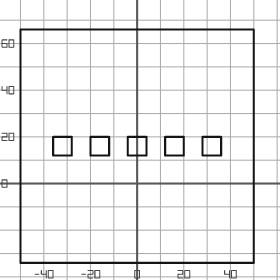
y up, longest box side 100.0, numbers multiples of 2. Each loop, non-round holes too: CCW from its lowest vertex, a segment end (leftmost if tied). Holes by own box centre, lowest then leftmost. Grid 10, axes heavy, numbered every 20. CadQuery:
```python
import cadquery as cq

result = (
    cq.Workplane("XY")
    .moveTo(-50.0, -34.0)
    .lineTo(50.0, -34.0)
    .lineTo(50.0, 66.0)
    .lineTo(-50.0, 66.0)
    .close()
    .moveTo(-36.0, 12.0)
    .lineTo(-28.0, 12.0)
    .lineTo(-28.0, 20.0)
    .lineTo(-36.0, 20.0)
    .close()
    .moveTo(-20.0, 12.0)
    .lineTo(-12.0, 12.0)
    .lineTo(-12.0, 20.0)
    .lineTo(-20.0, 20.0)
    .close()
    .moveTo(-4.0, 12.0)
    .lineTo(4.0, 12.0)
    .lineTo(4.0, 20.0)
    .lineTo(-4.0, 20.0)
    .close()
    .moveTo(12.0, 12.0)
    .lineTo(20.0, 12.0)
    .lineTo(20.0, 20.0)
    .lineTo(12.0, 20.0)
    .close()
    .moveTo(28.0, 12.0)
    .lineTo(36.0, 12.0)
    .lineTo(36.0, 20.0)
    .lineTo(28.0, 20.0)
    .close()
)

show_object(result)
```